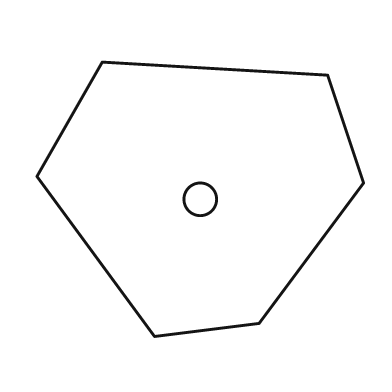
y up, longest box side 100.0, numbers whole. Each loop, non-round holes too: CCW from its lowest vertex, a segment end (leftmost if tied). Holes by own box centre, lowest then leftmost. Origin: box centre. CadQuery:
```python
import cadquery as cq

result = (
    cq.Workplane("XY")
    .moveTo(-14.0, -42.0)
    .lineTo(18.0, -38.0)
    .lineTo(50.0, 5.0)
    .lineTo(39.0, 38.0)
    .lineTo(-30.0, 42.0)
    .lineTo(-50.0, 7.0)
    .close()
    .moveTo(0.0, 0.0)
    .circle(5.0)
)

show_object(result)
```